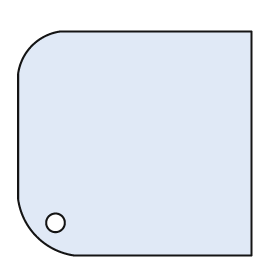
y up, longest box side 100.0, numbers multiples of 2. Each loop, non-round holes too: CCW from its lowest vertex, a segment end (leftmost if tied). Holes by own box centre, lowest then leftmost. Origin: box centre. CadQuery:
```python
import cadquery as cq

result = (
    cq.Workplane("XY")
    .moveTo(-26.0, -48.0)
    .lineTo(50.0, -48.0)
    .lineTo(50.0, 48.0)
    .lineTo(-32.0, 48.0)
    .threePointArc((-44.0, 42.0), (-50.0, 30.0))
    .lineTo(-50.0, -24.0)
    .threePointArc((-42.0, -40.0), (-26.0, -48.0))
    .close()
    .moveTo(-34.0, -34.0)
    .circle(4.0)
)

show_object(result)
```